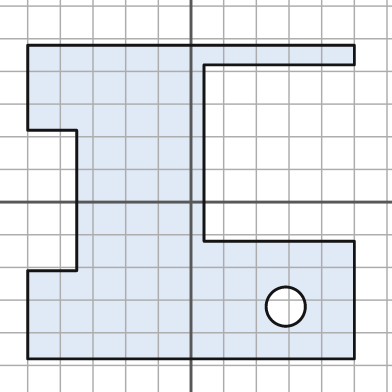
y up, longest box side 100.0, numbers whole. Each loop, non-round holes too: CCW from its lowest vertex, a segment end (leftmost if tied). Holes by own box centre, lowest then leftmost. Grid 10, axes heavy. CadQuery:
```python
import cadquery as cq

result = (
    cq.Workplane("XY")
    .moveTo(-50.0, -48.0)
    .lineTo(50.0, -48.0)
    .lineTo(50.0, -12.0)
    .lineTo(4.0, -12.0)
    .lineTo(4.0, 42.0)
    .lineTo(50.0, 42.0)
    .lineTo(50.0, 48.0)
    .lineTo(-50.0, 48.0)
    .lineTo(-50.0, 22.0)
    .lineTo(-35.0, 22.0)
    .lineTo(-35.0, -21.0)
    .lineTo(-50.0, -21.0)
    .close()
    .moveTo(29.0, -32.0)
    .circle(6.0)
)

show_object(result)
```